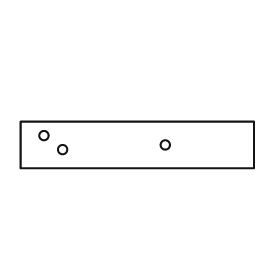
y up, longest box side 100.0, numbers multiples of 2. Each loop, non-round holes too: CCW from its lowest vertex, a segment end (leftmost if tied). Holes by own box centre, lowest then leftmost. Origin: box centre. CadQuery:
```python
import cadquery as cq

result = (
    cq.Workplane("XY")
    .moveTo(-50.0, -10.0)
    .lineTo(50.0, -10.0)
    .lineTo(50.0, 10.0)
    .lineTo(-50.0, 10.0)
    .close()
    .moveTo(-32.0, -2.0)
    .circle(2.0)
    .moveTo(12.0, 0.0)
    .circle(2.0)
    .moveTo(-40.0, 4.0)
    .circle(2.0)
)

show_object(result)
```